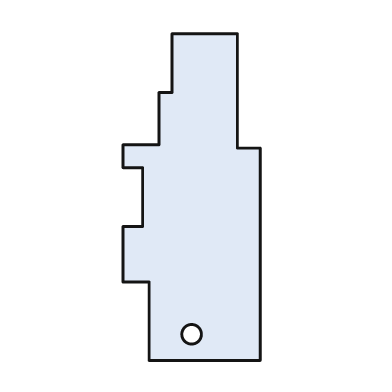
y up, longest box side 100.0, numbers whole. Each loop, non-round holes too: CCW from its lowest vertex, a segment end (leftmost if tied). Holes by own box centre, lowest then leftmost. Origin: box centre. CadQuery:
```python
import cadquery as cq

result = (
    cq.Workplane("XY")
    .moveTo(-13.0, -50.0)
    .lineTo(21.0, -50.0)
    .lineTo(21.0, 15.0)
    .lineTo(14.0, 15.0)
    .lineTo(14.0, 50.0)
    .lineTo(-6.0, 50.0)
    .lineTo(-6.0, 32.0)
    .lineTo(-10.0, 32.0)
    .lineTo(-10.0, 16.0)
    .lineTo(-21.0, 16.0)
    .lineTo(-21.0, 9.0)
    .lineTo(-15.0, 9.0)
    .lineTo(-15.0, -9.0)
    .lineTo(-21.0, -9.0)
    .lineTo(-21.0, -26.0)
    .lineTo(-13.0, -26.0)
    .close()
    .moveTo(0.0, -42.0)
    .circle(3.0)
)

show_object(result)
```